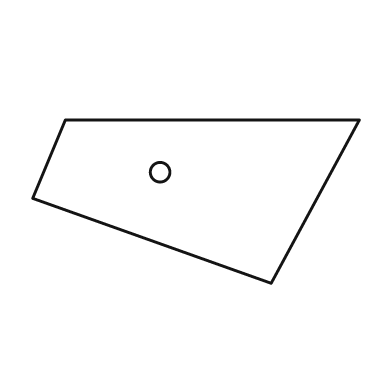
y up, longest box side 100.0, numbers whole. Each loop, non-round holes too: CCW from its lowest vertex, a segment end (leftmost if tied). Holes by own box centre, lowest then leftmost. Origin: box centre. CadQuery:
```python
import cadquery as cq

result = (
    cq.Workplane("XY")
    .moveTo(23.0, -25.0)
    .lineTo(50.0, 25.0)
    .lineTo(-40.0, 25.0)
    .lineTo(-50.0, 1.0)
    .close()
    .moveTo(-11.0, 9.0)
    .circle(3.0)
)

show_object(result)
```